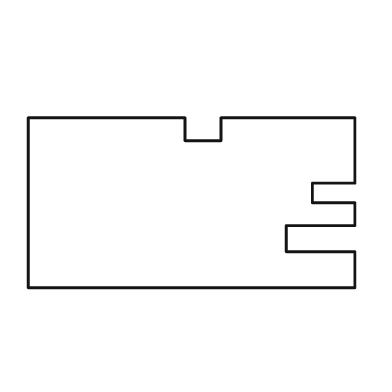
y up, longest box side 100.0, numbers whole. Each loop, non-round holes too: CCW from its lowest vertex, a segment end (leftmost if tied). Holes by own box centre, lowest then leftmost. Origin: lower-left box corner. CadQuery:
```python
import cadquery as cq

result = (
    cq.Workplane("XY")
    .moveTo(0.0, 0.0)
    .lineTo(100.0, 0.0)
    .lineTo(100.0, 11.0)
    .lineTo(79.0, 11.0)
    .lineTo(79.0, 19.0)
    .lineTo(100.0, 19.0)
    .lineTo(100.0, 26.0)
    .lineTo(87.0, 26.0)
    .lineTo(87.0, 32.0)
    .lineTo(100.0, 32.0)
    .lineTo(100.0, 52.0)
    .lineTo(59.0, 52.0)
    .lineTo(59.0, 45.0)
    .lineTo(48.0, 45.0)
    .lineTo(48.0, 52.0)
    .lineTo(0.0, 52.0)
    .close()
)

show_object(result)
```